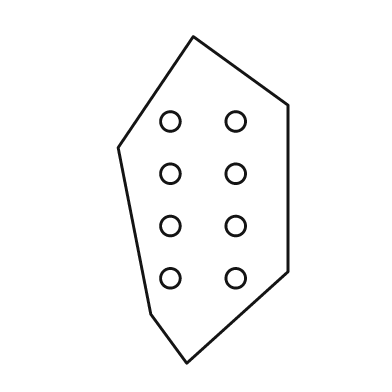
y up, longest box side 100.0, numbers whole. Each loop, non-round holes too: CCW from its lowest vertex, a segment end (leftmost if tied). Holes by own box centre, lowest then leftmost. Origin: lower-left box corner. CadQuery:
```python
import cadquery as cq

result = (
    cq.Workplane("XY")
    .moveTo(21.0, 0.0)
    .lineTo(52.0, 28.0)
    .lineTo(52.0, 79.0)
    .lineTo(23.0, 100.0)
    .lineTo(0.0, 66.0)
    .lineTo(10.0, 15.0)
    .close()
    .moveTo(16.0, 26.0)
    .circle(3.0)
    .moveTo(36.0, 26.0)
    .circle(3.0)
    .moveTo(16.0, 42.0)
    .circle(3.0)
    .moveTo(36.0, 42.0)
    .circle(3.0)
    .moveTo(16.0, 58.0)
    .circle(3.0)
    .moveTo(36.0, 58.0)
    .circle(3.0)
    .moveTo(16.0, 74.0)
    .circle(3.0)
    .moveTo(36.0, 74.0)
    .circle(3.0)
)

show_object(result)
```